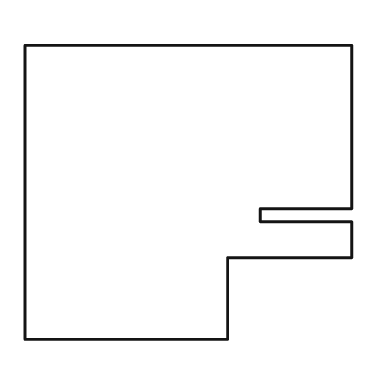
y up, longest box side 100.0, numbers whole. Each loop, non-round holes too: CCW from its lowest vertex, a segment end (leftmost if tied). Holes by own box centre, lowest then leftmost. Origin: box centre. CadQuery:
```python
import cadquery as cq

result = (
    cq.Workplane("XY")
    .moveTo(-50.0, -45.0)
    .lineTo(12.0, -45.0)
    .lineTo(12.0, -20.0)
    .lineTo(50.0, -20.0)
    .lineTo(50.0, -9.0)
    .lineTo(22.0, -9.0)
    .lineTo(22.0, -5.0)
    .lineTo(50.0, -5.0)
    .lineTo(50.0, 45.0)
    .lineTo(-50.0, 45.0)
    .close()
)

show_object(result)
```